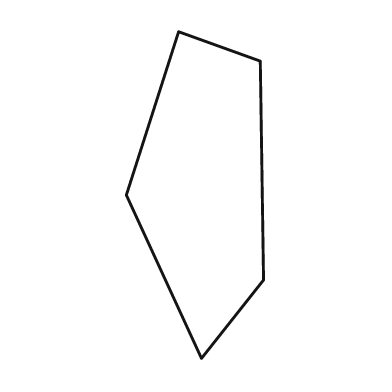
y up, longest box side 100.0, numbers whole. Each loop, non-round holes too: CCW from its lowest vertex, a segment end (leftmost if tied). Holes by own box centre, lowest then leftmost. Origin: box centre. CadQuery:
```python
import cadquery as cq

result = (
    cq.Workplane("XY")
    .moveTo(2.0, -50.0)
    .lineTo(21.0, -26.0)
    .lineTo(20.0, 41.0)
    .lineTo(-5.0, 50.0)
    .lineTo(-21.0, 0.0)
    .close()
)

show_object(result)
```